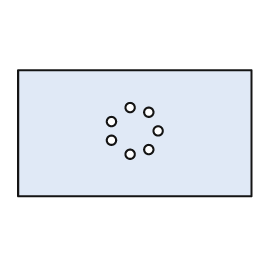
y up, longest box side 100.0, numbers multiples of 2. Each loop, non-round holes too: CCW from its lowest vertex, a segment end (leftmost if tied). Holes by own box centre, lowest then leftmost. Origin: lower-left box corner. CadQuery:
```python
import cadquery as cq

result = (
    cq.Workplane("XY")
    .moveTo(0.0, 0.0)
    .lineTo(100.0, 0.0)
    .lineTo(100.0, 54.0)
    .lineTo(0.0, 54.0)
    .close()
    .moveTo(48.0, 18.0)
    .circle(2.0)
    .moveTo(56.0, 20.0)
    .circle(2.0)
    .moveTo(40.0, 24.0)
    .circle(2.0)
    .moveTo(60.0, 28.0)
    .circle(2.0)
    .moveTo(40.0, 32.0)
    .circle(2.0)
    .moveTo(56.0, 36.0)
    .circle(2.0)
    .moveTo(48.0, 38.0)
    .circle(2.0)
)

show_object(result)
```